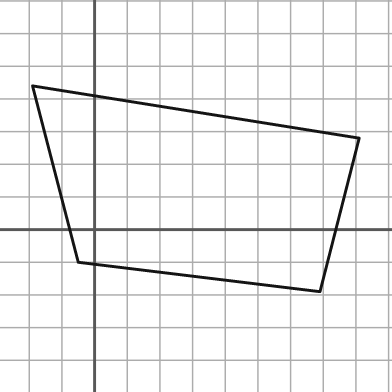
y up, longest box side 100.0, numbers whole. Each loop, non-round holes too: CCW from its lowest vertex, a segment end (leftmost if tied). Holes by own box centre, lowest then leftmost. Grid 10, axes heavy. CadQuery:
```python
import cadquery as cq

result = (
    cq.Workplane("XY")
    .moveTo(69.0, -19.0)
    .lineTo(81.0, 28.0)
    .lineTo(-19.0, 44.0)
    .lineTo(-5.0, -10.0)
    .close()
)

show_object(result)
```